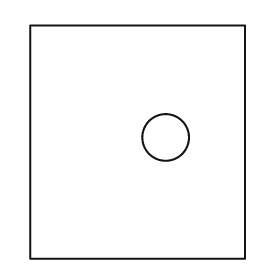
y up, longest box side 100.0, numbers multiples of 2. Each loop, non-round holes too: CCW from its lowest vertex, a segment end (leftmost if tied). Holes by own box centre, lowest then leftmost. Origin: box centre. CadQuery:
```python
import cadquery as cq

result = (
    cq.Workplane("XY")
    .moveTo(-46.0, -50.0)
    .lineTo(46.0, -50.0)
    .lineTo(46.0, 50.0)
    .lineTo(-46.0, 50.0)
    .close()
    .moveTo(12.0, 2.0)
    .circle(10.0)
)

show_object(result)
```